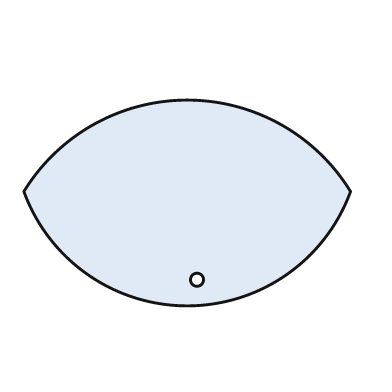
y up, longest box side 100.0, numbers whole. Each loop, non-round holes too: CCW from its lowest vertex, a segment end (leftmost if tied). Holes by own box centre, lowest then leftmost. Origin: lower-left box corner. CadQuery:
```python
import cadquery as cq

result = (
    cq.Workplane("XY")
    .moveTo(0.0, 35.0)
    .threePointArc((50.0, 0.0), (100.0, 35.0))
    .threePointArc((50.0, 63.0), (0.0, 35.0))
    .close()
    .moveTo(53.0, 8.0)
    .circle(2.0)
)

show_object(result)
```